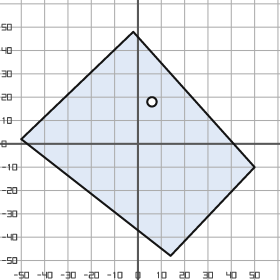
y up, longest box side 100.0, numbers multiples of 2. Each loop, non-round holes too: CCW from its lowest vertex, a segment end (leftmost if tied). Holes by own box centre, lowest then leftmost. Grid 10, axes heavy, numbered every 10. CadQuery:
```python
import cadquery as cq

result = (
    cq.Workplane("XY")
    .moveTo(14.0, -48.0)
    .lineTo(50.0, -10.0)
    .lineTo(-2.0, 48.0)
    .lineTo(-50.0, 2.0)
    .close()
    .moveTo(6.0, 18.0)
    .circle(2.0)
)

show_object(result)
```